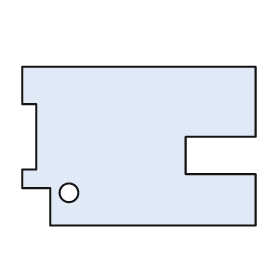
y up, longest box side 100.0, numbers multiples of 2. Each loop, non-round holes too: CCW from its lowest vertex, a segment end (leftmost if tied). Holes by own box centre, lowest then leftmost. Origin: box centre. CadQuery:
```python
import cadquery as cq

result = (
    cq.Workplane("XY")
    .moveTo(-38.0, -34.0)
    .lineTo(50.0, -34.0)
    .lineTo(50.0, -12.0)
    .lineTo(20.0, -12.0)
    .lineTo(20.0, 4.0)
    .lineTo(50.0, 4.0)
    .lineTo(50.0, 34.0)
    .lineTo(-50.0, 34.0)
    .lineTo(-50.0, 18.0)
    .lineTo(-44.0, 18.0)
    .lineTo(-44.0, -10.0)
    .lineTo(-50.0, -10.0)
    .lineTo(-50.0, -18.0)
    .lineTo(-38.0, -18.0)
    .close()
    .moveTo(-30.0, -20.0)
    .circle(4.0)
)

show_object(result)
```